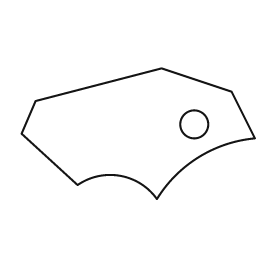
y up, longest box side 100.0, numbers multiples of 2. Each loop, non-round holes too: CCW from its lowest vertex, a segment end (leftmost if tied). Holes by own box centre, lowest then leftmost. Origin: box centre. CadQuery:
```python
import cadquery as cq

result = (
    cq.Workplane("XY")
    .moveTo(8.0, -28.0)
    .threePointArc((26.0, -10.0), (50.0, -2.0))
    .lineTo(40.0, 18.0)
    .lineTo(10.0, 28.0)
    .lineTo(-44.0, 14.0)
    .lineTo(-50.0, 0.0)
    .lineTo(-26.0, -22.0)
    .threePointArc((-8.0, -18.0), (8.0, -28.0))
    .close()
    .moveTo(24.0, 4.0)
    .circle(6.0)
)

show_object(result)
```